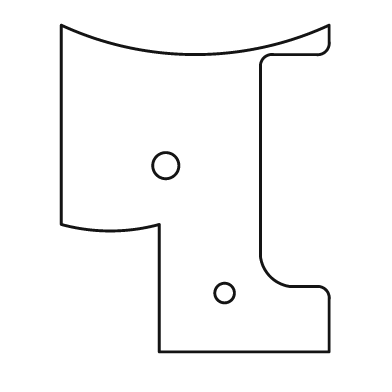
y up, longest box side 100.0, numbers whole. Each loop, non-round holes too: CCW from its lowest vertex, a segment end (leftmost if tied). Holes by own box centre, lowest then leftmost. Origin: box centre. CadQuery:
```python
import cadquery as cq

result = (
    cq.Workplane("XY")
    .moveTo(-11.0, -50.0)
    .lineTo(41.0, -50.0)
    .lineTo(41.0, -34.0)
    .threePointArc((40.0, -31.0), (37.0, -30.0))
    .lineTo(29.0, -30.0)
    .threePointArc((23.0, -27.0), (20.0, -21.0))
    .lineTo(20.0, 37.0)
    .threePointArc((21.0, 40.0), (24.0, 41.0))
    .lineTo(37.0, 41.0)
    .threePointArc((40.0, 42.0), (41.0, 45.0))
    .lineTo(41.0, 50.0)
    .threePointArc((0.0, 41.0), (-41.0, 50.0))
    .lineTo(-41.0, -11.0)
    .threePointArc((-26.0, -13.0), (-11.0, -11.0))
    .close()
    .moveTo(9.0, -32.0)
    .circle(3.0)
    .moveTo(-9.0, 7.0)
    .circle(4.0)
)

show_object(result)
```